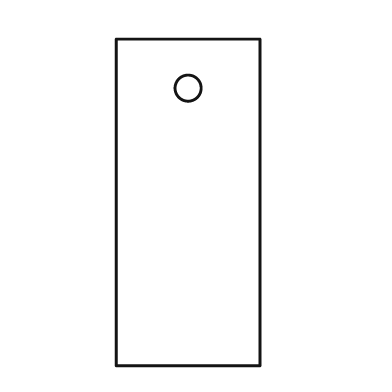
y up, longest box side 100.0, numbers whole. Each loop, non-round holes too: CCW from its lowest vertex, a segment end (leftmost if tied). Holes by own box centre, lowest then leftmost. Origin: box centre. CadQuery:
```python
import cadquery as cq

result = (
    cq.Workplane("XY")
    .moveTo(-22.0, -50.0)
    .lineTo(22.0, -50.0)
    .lineTo(22.0, 50.0)
    .lineTo(-22.0, 50.0)
    .close()
    .moveTo(0.0, 35.0)
    .circle(4.0)
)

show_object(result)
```